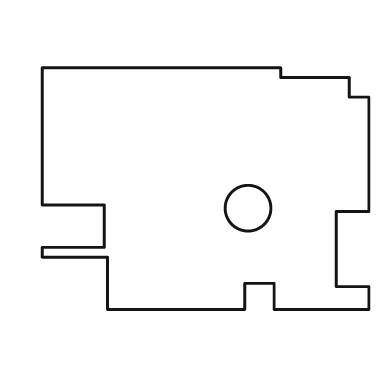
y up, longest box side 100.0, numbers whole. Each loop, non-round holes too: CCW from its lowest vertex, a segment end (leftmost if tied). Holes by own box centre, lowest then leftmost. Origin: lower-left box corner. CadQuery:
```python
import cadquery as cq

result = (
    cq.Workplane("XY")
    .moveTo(20.0, 0.0)
    .lineTo(62.0, 0.0)
    .lineTo(62.0, 8.0)
    .lineTo(71.0, 8.0)
    .lineTo(71.0, 0.0)
    .lineTo(100.0, 0.0)
    .lineTo(100.0, 7.0)
    .lineTo(90.0, 7.0)
    .lineTo(90.0, 30.0)
    .lineTo(100.0, 30.0)
    .lineTo(100.0, 65.0)
    .lineTo(94.0, 65.0)
    .lineTo(94.0, 71.0)
    .lineTo(73.0, 71.0)
    .lineTo(73.0, 74.0)
    .lineTo(0.0, 74.0)
    .lineTo(0.0, 32.0)
    .lineTo(19.0, 32.0)
    .lineTo(19.0, 19.0)
    .lineTo(0.0, 19.0)
    .lineTo(0.0, 16.0)
    .lineTo(20.0, 16.0)
    .close()
    .moveTo(63.0, 31.0)
    .circle(7.0)
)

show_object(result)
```